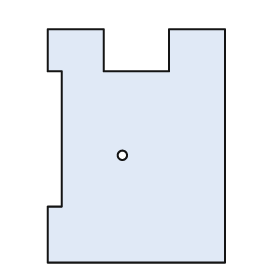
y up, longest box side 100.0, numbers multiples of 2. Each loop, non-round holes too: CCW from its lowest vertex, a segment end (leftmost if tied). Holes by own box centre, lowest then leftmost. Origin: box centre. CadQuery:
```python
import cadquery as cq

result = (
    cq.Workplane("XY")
    .moveTo(-38.0, -50.0)
    .lineTo(38.0, -50.0)
    .lineTo(38.0, 50.0)
    .lineTo(14.0, 50.0)
    .lineTo(14.0, 32.0)
    .lineTo(-14.0, 32.0)
    .lineTo(-14.0, 50.0)
    .lineTo(-38.0, 50.0)
    .lineTo(-38.0, 32.0)
    .lineTo(-32.0, 32.0)
    .lineTo(-32.0, -26.0)
    .lineTo(-38.0, -26.0)
    .close()
    .moveTo(-6.0, -4.0)
    .circle(2.0)
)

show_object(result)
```